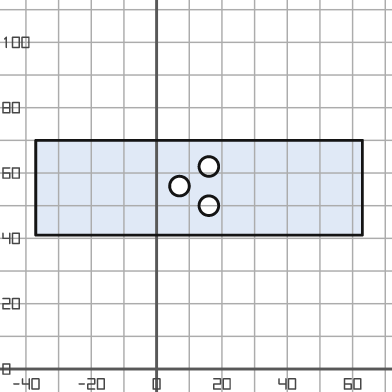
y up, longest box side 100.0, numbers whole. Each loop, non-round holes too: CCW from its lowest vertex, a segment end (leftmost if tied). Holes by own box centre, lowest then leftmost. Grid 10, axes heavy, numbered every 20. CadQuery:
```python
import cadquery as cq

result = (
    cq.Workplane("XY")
    .moveTo(-37.0, 41.0)
    .lineTo(63.0, 41.0)
    .lineTo(63.0, 70.0)
    .lineTo(-37.0, 70.0)
    .close()
    .moveTo(16.0, 50.0)
    .circle(3.0)
    .moveTo(7.0, 56.0)
    .circle(3.0)
    .moveTo(16.0, 62.0)
    .circle(3.0)
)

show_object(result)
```